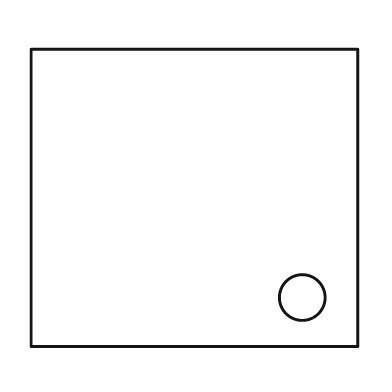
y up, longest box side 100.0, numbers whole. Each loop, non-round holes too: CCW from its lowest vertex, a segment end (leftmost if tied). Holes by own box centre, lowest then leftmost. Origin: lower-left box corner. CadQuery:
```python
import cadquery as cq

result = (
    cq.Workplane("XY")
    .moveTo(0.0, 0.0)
    .lineTo(100.0, 0.0)
    .lineTo(100.0, 91.0)
    .lineTo(0.0, 91.0)
    .close()
    .moveTo(83.0, 15.0)
    .circle(7.0)
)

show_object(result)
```